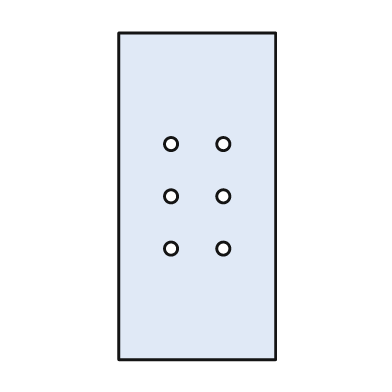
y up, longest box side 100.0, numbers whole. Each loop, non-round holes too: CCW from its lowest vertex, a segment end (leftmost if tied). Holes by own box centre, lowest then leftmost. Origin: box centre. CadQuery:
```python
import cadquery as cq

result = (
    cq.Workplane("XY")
    .moveTo(-24.0, -50.0)
    .lineTo(24.0, -50.0)
    .lineTo(24.0, 50.0)
    .lineTo(-24.0, 50.0)
    .close()
    .moveTo(-8.0, -16.0)
    .circle(2.0)
    .moveTo(8.0, -16.0)
    .circle(2.0)
    .moveTo(-8.0, 0.0)
    .circle(2.0)
    .moveTo(8.0, 0.0)
    .circle(2.0)
    .moveTo(-8.0, 16.0)
    .circle(2.0)
    .moveTo(8.0, 16.0)
    .circle(2.0)
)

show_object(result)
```